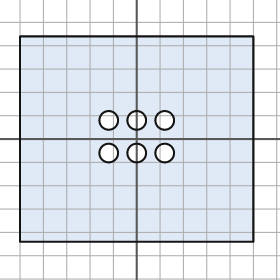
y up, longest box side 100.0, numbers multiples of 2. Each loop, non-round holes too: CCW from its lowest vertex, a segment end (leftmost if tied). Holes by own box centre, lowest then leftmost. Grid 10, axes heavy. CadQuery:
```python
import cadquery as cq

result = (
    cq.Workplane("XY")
    .moveTo(-50.0, -44.0)
    .lineTo(50.0, -44.0)
    .lineTo(50.0, 44.0)
    .lineTo(-50.0, 44.0)
    .close()
    .moveTo(-12.0, -6.0)
    .circle(4.0)
    .moveTo(0.0, -6.0)
    .circle(4.0)
    .moveTo(12.0, -6.0)
    .circle(4.0)
    .moveTo(-12.0, 8.0)
    .circle(4.0)
    .moveTo(0.0, 8.0)
    .circle(4.0)
    .moveTo(12.0, 8.0)
    .circle(4.0)
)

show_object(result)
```